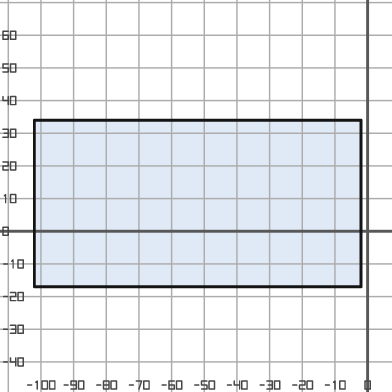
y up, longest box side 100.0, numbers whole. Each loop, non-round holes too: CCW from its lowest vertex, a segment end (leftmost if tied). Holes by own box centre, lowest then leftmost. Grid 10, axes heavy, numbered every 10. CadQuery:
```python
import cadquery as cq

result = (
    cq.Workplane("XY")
    .moveTo(-102.0, -17.0)
    .lineTo(-2.0, -17.0)
    .lineTo(-2.0, 34.0)
    .lineTo(-102.0, 34.0)
    .close()
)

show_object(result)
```